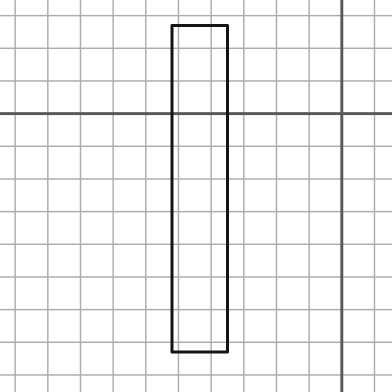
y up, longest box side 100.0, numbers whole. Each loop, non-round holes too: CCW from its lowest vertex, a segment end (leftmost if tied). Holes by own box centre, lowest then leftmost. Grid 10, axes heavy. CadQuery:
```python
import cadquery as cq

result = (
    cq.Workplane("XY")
    .moveTo(-52.0, -73.0)
    .lineTo(-35.0, -73.0)
    .lineTo(-35.0, 27.0)
    .lineTo(-52.0, 27.0)
    .close()
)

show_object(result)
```